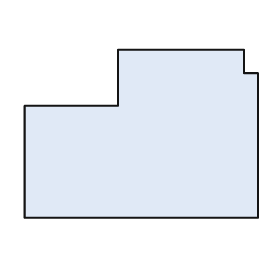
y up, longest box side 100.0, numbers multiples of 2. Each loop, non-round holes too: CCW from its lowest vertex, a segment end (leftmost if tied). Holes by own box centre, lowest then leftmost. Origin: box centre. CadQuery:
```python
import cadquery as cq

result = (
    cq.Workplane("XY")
    .moveTo(-50.0, -36.0)
    .lineTo(50.0, -36.0)
    .lineTo(50.0, 26.0)
    .lineTo(44.0, 26.0)
    .lineTo(44.0, 36.0)
    .lineTo(-10.0, 36.0)
    .lineTo(-10.0, 12.0)
    .lineTo(-50.0, 12.0)
    .close()
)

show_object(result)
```